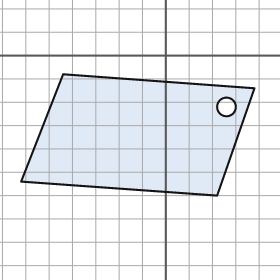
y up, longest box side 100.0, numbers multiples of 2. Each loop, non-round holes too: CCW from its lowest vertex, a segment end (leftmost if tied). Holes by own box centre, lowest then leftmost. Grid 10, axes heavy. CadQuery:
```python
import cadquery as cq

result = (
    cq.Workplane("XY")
    .moveTo(22.0, -60.0)
    .lineTo(38.0, -14.0)
    .lineTo(-44.0, -8.0)
    .lineTo(-62.0, -54.0)
    .close()
    .moveTo(26.0, -22.0)
    .circle(4.0)
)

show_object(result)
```